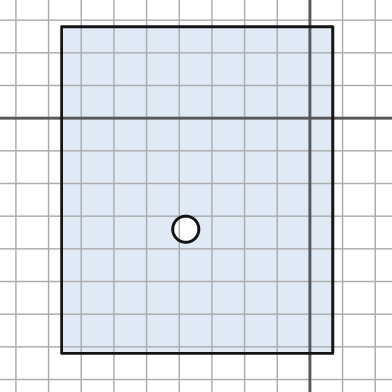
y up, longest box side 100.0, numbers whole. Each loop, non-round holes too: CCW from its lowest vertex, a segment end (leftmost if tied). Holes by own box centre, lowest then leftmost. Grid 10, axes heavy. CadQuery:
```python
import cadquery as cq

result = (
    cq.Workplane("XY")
    .moveTo(-76.0, -72.0)
    .lineTo(7.0, -72.0)
    .lineTo(7.0, 28.0)
    .lineTo(-76.0, 28.0)
    .close()
    .moveTo(-38.0, -34.0)
    .circle(4.0)
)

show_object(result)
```